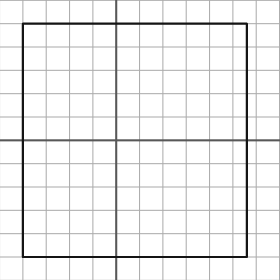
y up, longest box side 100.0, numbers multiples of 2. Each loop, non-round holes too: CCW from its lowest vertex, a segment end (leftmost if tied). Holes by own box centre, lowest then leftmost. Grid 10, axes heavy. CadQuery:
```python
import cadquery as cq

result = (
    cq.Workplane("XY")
    .moveTo(-40.0, -50.0)
    .lineTo(56.0, -50.0)
    .lineTo(56.0, 50.0)
    .lineTo(-40.0, 50.0)
    .close()
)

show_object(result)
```